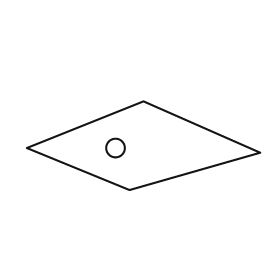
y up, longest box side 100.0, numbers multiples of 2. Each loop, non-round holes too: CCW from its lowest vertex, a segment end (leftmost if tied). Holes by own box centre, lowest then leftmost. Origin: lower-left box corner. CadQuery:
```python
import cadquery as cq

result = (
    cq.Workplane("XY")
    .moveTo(44.0, 0.0)
    .lineTo(100.0, 16.0)
    .lineTo(50.0, 38.0)
    .lineTo(0.0, 18.0)
    .close()
    .moveTo(38.0, 18.0)
    .circle(4.0)
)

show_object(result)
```